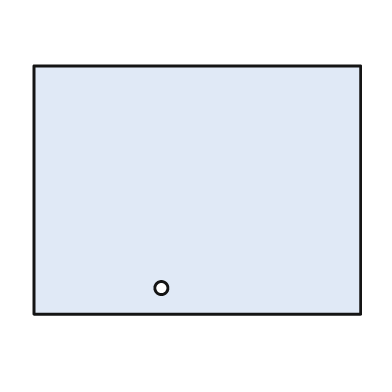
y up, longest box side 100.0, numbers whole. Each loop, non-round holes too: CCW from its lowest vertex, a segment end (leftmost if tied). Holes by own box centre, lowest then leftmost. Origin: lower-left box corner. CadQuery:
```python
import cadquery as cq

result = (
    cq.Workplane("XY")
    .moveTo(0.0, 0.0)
    .lineTo(100.0, 0.0)
    .lineTo(100.0, 76.0)
    .lineTo(0.0, 76.0)
    .close()
    .moveTo(39.0, 8.0)
    .circle(2.0)
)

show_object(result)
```